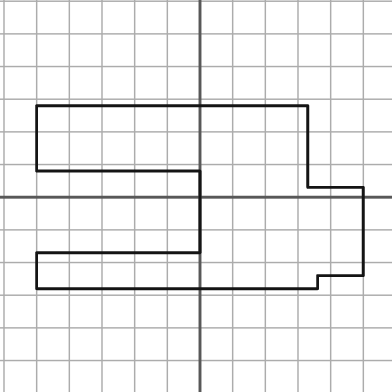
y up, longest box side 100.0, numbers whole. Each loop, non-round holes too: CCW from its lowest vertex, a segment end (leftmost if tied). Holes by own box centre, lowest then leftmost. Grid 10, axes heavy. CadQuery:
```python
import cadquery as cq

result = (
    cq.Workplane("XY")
    .moveTo(-50.0, -28.0)
    .lineTo(36.0, -28.0)
    .lineTo(36.0, -24.0)
    .lineTo(50.0, -24.0)
    .lineTo(50.0, 3.0)
    .lineTo(33.0, 3.0)
    .lineTo(33.0, 28.0)
    .lineTo(-50.0, 28.0)
    .lineTo(-50.0, 8.0)
    .lineTo(0.0, 8.0)
    .lineTo(0.0, -17.0)
    .lineTo(-50.0, -17.0)
    .close()
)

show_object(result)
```